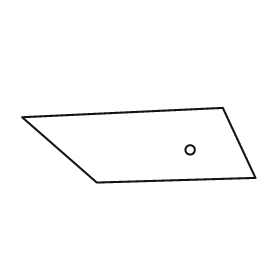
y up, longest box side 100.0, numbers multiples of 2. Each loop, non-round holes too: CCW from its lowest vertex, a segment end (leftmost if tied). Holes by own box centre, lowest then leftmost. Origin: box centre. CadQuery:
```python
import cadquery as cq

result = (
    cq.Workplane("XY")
    .moveTo(-18.0, -16.0)
    .lineTo(50.0, -14.0)
    .lineTo(36.0, 16.0)
    .lineTo(-50.0, 12.0)
    .close()
    .moveTo(22.0, -2.0)
    .circle(2.0)
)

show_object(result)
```